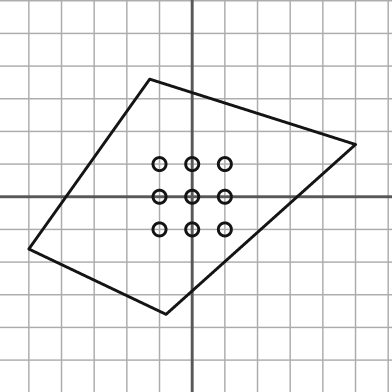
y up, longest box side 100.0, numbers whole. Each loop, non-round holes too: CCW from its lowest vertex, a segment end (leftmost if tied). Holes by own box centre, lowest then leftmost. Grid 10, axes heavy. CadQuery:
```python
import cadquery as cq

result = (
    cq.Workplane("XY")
    .moveTo(-8.0, -36.0)
    .lineTo(50.0, 16.0)
    .lineTo(-13.0, 36.0)
    .lineTo(-50.0, -16.0)
    .close()
    .moveTo(-10.0, -10.0)
    .circle(2.0)
    .moveTo(0.0, -10.0)
    .circle(2.0)
    .moveTo(10.0, -10.0)
    .circle(2.0)
    .moveTo(-10.0, 0.0)
    .circle(2.0)
    .moveTo(0.0, 0.0)
    .circle(2.0)
    .moveTo(10.0, 0.0)
    .circle(2.0)
    .moveTo(-10.0, 10.0)
    .circle(2.0)
    .moveTo(0.0, 10.0)
    .circle(2.0)
    .moveTo(10.0, 10.0)
    .circle(2.0)
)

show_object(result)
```